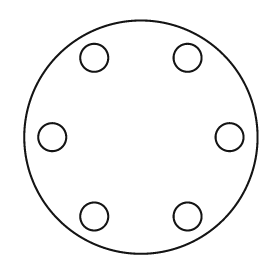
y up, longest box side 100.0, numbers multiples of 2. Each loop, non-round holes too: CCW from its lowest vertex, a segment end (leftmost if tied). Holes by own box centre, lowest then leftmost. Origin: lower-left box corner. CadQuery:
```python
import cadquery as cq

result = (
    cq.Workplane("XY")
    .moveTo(50.0, 50.0)
    .circle(50.0)
    .moveTo(30.0, 16.0)
    .circle(6.0)
    .moveTo(70.0, 16.0)
    .circle(6.0)
    .moveTo(12.0, 50.0)
    .circle(6.0)
    .moveTo(88.0, 50.0)
    .circle(6.0)
    .moveTo(30.0, 84.0)
    .circle(6.0)
    .moveTo(70.0, 84.0)
    .circle(6.0)
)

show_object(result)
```